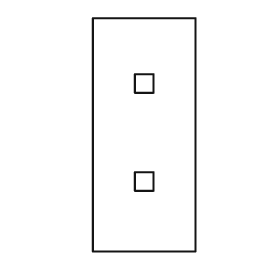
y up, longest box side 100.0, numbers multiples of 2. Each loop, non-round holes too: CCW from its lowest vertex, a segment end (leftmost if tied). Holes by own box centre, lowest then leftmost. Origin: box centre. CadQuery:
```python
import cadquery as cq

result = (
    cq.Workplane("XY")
    .moveTo(-22.0, -50.0)
    .lineTo(22.0, -50.0)
    .lineTo(22.0, 50.0)
    .lineTo(-22.0, 50.0)
    .close()
    .moveTo(-4.0, -24.0)
    .lineTo(4.0, -24.0)
    .lineTo(4.0, -16.0)
    .lineTo(-4.0, -16.0)
    .close()
    .moveTo(-4.0, 18.0)
    .lineTo(4.0, 18.0)
    .lineTo(4.0, 26.0)
    .lineTo(-4.0, 26.0)
    .close()
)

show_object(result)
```